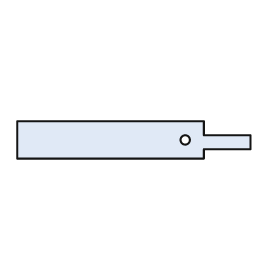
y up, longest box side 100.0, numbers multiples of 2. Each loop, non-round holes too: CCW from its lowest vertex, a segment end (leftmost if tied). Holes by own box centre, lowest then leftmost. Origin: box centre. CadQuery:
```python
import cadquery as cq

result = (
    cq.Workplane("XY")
    .moveTo(-50.0, -8.0)
    .lineTo(30.0, -8.0)
    .lineTo(30.0, -4.0)
    .lineTo(50.0, -4.0)
    .lineTo(50.0, 2.0)
    .lineTo(30.0, 2.0)
    .lineTo(30.0, 8.0)
    .lineTo(-50.0, 8.0)
    .close()
    .moveTo(22.0, 0.0)
    .circle(2.0)
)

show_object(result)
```